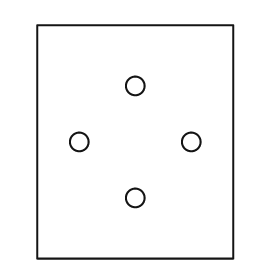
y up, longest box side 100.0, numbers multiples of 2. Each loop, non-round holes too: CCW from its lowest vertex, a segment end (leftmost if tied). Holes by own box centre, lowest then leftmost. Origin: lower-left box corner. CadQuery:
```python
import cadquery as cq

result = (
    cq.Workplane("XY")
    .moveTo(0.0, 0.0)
    .lineTo(84.0, 0.0)
    .lineTo(84.0, 100.0)
    .lineTo(0.0, 100.0)
    .close()
    .moveTo(42.0, 26.0)
    .circle(4.0)
    .moveTo(18.0, 50.0)
    .circle(4.0)
    .moveTo(66.0, 50.0)
    .circle(4.0)
    .moveTo(42.0, 74.0)
    .circle(4.0)
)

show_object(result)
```